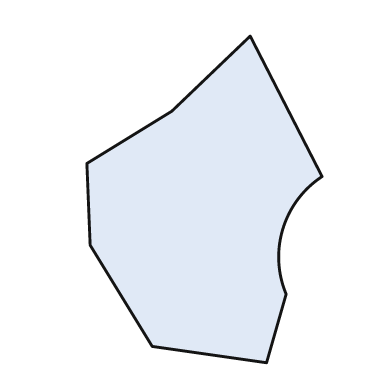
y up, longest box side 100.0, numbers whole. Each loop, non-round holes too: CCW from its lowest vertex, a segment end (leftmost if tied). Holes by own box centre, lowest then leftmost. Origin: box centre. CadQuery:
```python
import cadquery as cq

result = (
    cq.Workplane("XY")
    .moveTo(19.0, -50.0)
    .lineTo(25.0, -29.0)
    .threePointArc((24.0, -9.0), (36.0, 7.0))
    .lineTo(14.0, 50.0)
    .lineTo(-10.0, 27.0)
    .lineTo(-36.0, 11.0)
    .lineTo(-35.0, -14.0)
    .lineTo(-16.0, -45.0)
    .close()
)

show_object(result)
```